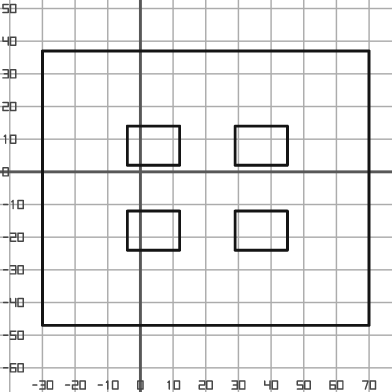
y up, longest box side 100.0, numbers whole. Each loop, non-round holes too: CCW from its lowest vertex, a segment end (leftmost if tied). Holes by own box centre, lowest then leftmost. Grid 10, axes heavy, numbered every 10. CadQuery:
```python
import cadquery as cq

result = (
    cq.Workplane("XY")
    .moveTo(-30.0, -47.0)
    .lineTo(70.0, -47.0)
    .lineTo(70.0, 37.0)
    .lineTo(-30.0, 37.0)
    .close()
    .moveTo(-4.0, -24.0)
    .lineTo(12.0, -24.0)
    .lineTo(12.0, -12.0)
    .lineTo(-4.0, -12.0)
    .close()
    .moveTo(29.0, -24.0)
    .lineTo(45.0, -24.0)
    .lineTo(45.0, -12.0)
    .lineTo(29.0, -12.0)
    .close()
    .moveTo(-4.0, 2.0)
    .lineTo(12.0, 2.0)
    .lineTo(12.0, 14.0)
    .lineTo(-4.0, 14.0)
    .close()
    .moveTo(29.0, 2.0)
    .lineTo(45.0, 2.0)
    .lineTo(45.0, 14.0)
    .lineTo(29.0, 14.0)
    .close()
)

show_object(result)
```